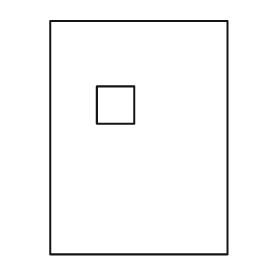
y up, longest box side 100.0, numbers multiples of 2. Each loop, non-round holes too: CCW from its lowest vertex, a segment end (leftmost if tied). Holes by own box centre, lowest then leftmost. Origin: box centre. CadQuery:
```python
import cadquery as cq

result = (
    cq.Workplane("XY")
    .moveTo(-38.0, -50.0)
    .lineTo(38.0, -50.0)
    .lineTo(38.0, 50.0)
    .lineTo(-38.0, 50.0)
    .close()
    .moveTo(-18.0, 6.0)
    .lineTo(-2.0, 6.0)
    .lineTo(-2.0, 22.0)
    .lineTo(-18.0, 22.0)
    .close()
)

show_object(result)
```